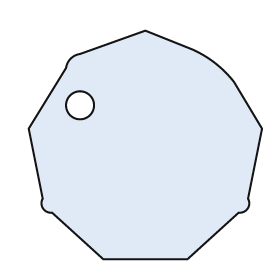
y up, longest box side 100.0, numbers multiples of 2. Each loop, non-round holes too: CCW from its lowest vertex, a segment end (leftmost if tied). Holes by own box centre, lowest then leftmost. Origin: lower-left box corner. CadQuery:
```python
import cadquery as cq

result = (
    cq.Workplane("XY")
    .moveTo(32.0, 0.0)
    .lineTo(68.0, 0.0)
    .lineTo(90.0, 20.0)
    .threePointArc((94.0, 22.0), (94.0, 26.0))
    .lineTo(100.0, 56.0)
    .lineTo(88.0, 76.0)
    .threePointArc((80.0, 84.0), (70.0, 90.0))
    .lineTo(50.0, 98.0)
    .lineTo(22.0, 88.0)
    .threePointArc((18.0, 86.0), (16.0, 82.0))
    .lineTo(0.0, 56.0)
    .lineTo(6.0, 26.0)
    .threePointArc((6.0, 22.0), (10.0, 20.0))
    .close()
    .moveTo(22.0, 66.0)
    .circle(6.0)
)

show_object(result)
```